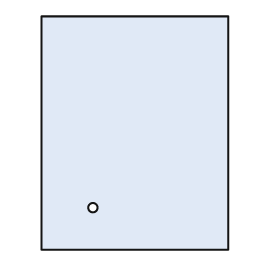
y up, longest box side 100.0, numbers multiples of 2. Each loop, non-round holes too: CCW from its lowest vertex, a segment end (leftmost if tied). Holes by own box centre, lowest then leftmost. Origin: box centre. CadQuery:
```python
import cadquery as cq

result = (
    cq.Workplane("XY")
    .moveTo(-40.0, -50.0)
    .lineTo(40.0, -50.0)
    .lineTo(40.0, 50.0)
    .lineTo(-40.0, 50.0)
    .close()
    .moveTo(-18.0, -32.0)
    .circle(2.0)
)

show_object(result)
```